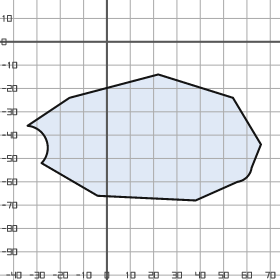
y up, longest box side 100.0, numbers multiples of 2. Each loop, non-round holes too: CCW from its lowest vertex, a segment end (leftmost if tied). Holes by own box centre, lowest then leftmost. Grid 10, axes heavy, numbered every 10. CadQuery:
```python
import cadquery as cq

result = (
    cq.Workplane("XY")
    .moveTo(38.0, -68.0)
    .lineTo(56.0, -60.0)
    .threePointArc((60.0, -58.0), (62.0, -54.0))
    .lineTo(66.0, -44.0)
    .lineTo(54.0, -24.0)
    .lineTo(22.0, -14.0)
    .lineTo(-16.0, -24.0)
    .lineTo(-34.0, -36.0)
    .threePointArc((-26.0, -42.0), (-28.0, -52.0))
    .lineTo(-4.0, -66.0)
    .close()
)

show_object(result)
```